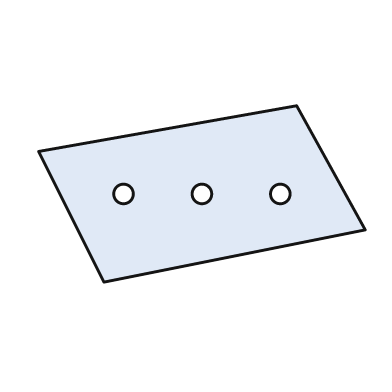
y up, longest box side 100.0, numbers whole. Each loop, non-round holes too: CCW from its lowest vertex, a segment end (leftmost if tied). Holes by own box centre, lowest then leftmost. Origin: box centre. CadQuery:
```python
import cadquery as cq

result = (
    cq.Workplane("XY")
    .moveTo(-30.0, -27.0)
    .lineTo(50.0, -11.0)
    .lineTo(29.0, 27.0)
    .lineTo(-50.0, 13.0)
    .close()
    .moveTo(-24.0, 0.0)
    .circle(3.0)
    .moveTo(0.0, 0.0)
    .circle(3.0)
    .moveTo(24.0, 0.0)
    .circle(3.0)
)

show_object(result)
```